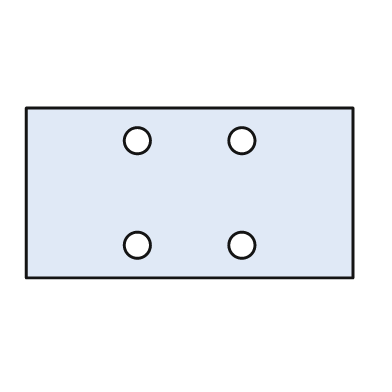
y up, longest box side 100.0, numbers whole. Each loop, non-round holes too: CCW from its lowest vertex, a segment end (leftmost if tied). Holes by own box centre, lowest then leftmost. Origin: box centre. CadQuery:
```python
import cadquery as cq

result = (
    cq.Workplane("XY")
    .moveTo(-50.0, -26.0)
    .lineTo(50.0, -26.0)
    .lineTo(50.0, 26.0)
    .lineTo(-50.0, 26.0)
    .close()
    .moveTo(-16.0, -16.0)
    .circle(4.0)
    .moveTo(16.0, -16.0)
    .circle(4.0)
    .moveTo(-16.0, 16.0)
    .circle(4.0)
    .moveTo(16.0, 16.0)
    .circle(4.0)
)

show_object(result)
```